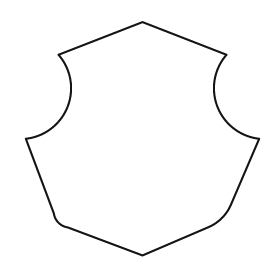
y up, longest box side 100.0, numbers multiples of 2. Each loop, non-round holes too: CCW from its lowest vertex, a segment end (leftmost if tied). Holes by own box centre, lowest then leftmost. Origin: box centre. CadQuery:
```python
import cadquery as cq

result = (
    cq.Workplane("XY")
    .moveTo(0.0, -50.0)
    .lineTo(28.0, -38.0)
    .threePointArc((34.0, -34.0), (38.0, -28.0))
    .lineTo(50.0, 0.0)
    .threePointArc((32.0, 14.0), (36.0, 36.0))
    .lineTo(0.0, 50.0)
    .lineTo(-36.0, 36.0)
    .threePointArc((-32.0, 14.0), (-50.0, 0.0))
    .lineTo(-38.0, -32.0)
    .threePointArc((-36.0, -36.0), (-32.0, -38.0))
    .close()
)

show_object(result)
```